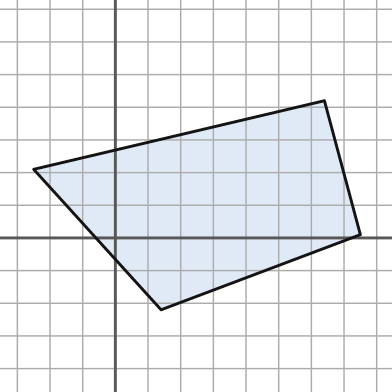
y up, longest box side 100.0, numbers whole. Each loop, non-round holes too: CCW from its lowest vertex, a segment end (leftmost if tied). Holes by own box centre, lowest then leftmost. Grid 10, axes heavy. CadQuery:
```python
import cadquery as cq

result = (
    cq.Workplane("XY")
    .moveTo(14.0, -22.0)
    .lineTo(75.0, 1.0)
    .lineTo(64.0, 42.0)
    .lineTo(-25.0, 21.0)
    .close()
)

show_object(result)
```